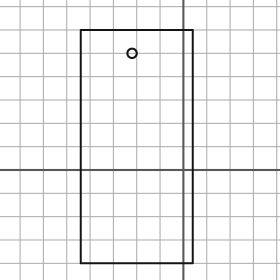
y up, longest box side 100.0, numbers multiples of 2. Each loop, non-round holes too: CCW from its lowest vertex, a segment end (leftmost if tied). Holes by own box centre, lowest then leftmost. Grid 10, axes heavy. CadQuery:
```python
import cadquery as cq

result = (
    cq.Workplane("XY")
    .moveTo(-44.0, -40.0)
    .lineTo(4.0, -40.0)
    .lineTo(4.0, 60.0)
    .lineTo(-44.0, 60.0)
    .close()
    .moveTo(-22.0, 50.0)
    .circle(2.0)
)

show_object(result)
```